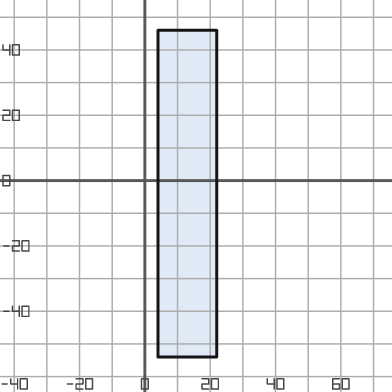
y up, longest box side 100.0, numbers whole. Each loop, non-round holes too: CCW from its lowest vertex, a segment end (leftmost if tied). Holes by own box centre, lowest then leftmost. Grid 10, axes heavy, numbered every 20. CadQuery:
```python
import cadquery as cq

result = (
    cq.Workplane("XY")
    .moveTo(4.0, -54.0)
    .lineTo(22.0, -54.0)
    .lineTo(22.0, 46.0)
    .lineTo(4.0, 46.0)
    .close()
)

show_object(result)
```